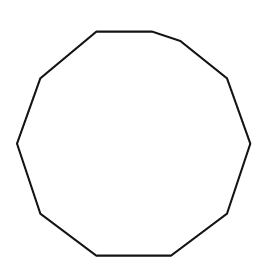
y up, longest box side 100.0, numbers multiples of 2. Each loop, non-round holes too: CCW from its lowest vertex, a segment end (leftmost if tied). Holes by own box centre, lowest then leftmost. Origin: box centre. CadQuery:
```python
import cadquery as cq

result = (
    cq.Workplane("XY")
    .moveTo(-16.0, -48.0)
    .lineTo(16.0, -48.0)
    .lineTo(40.0, -30.0)
    .lineTo(50.0, 0.0)
    .lineTo(40.0, 28.0)
    .lineTo(20.0, 44.0)
    .lineTo(8.0, 48.0)
    .lineTo(-16.0, 48.0)
    .lineTo(-40.0, 28.0)
    .lineTo(-50.0, 0.0)
    .lineTo(-40.0, -30.0)
    .close()
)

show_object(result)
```